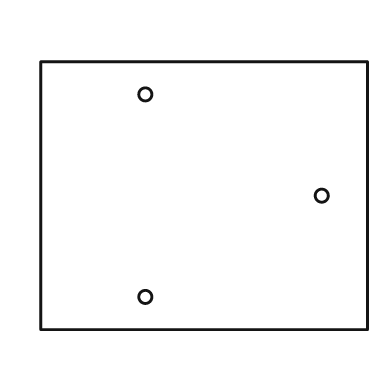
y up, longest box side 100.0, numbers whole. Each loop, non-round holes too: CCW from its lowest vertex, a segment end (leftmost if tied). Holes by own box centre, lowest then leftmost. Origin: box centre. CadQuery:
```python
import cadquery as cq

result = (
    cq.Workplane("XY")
    .moveTo(-50.0, -41.0)
    .lineTo(50.0, -41.0)
    .lineTo(50.0, 41.0)
    .lineTo(-50.0, 41.0)
    .close()
    .moveTo(-18.0, -31.0)
    .circle(2.0)
    .moveTo(36.0, 0.0)
    .circle(2.0)
    .moveTo(-18.0, 31.0)
    .circle(2.0)
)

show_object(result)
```